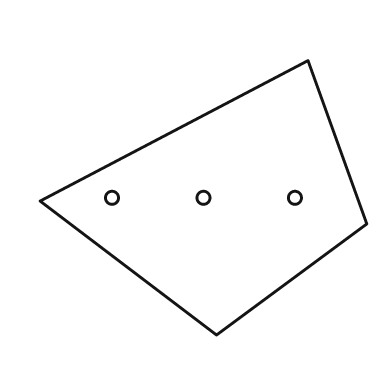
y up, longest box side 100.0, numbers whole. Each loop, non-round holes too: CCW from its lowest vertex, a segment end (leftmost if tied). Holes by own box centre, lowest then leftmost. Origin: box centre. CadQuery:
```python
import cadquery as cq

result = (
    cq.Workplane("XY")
    .moveTo(4.0, -42.0)
    .lineTo(50.0, -8.0)
    .lineTo(32.0, 42.0)
    .lineTo(-50.0, -1.0)
    .close()
    .moveTo(-28.0, 0.0)
    .circle(2.0)
    .moveTo(0.0, 0.0)
    .circle(2.0)
    .moveTo(28.0, 0.0)
    .circle(2.0)
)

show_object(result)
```